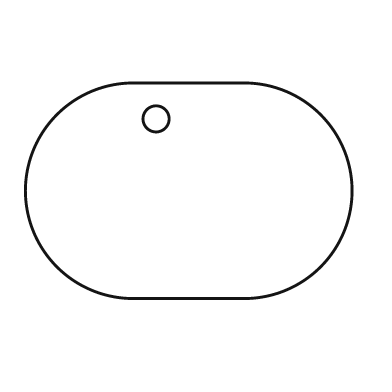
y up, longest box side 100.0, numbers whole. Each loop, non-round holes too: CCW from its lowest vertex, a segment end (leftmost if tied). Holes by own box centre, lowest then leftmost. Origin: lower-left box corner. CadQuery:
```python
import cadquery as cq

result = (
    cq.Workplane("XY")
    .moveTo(33.0, 0.0)
    .lineTo(67.0, 0.0)
    .threePointArc((100.0, 33.0), (67.0, 66.0))
    .lineTo(33.0, 66.0)
    .threePointArc((0.0, 33.0), (33.0, 0.0))
    .close()
    .moveTo(40.0, 55.0)
    .circle(4.0)
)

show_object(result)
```